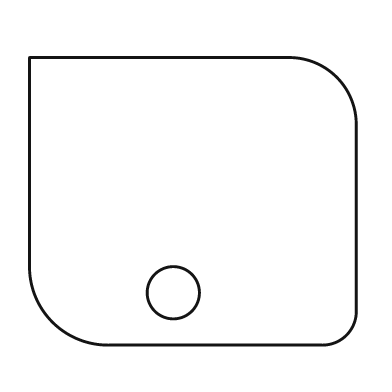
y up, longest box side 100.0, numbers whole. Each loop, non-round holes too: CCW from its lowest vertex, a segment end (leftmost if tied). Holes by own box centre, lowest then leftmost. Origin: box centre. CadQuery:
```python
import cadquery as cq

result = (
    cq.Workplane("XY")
    .moveTo(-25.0, -44.0)
    .lineTo(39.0, -44.0)
    .threePointArc((47.0, -41.0), (50.0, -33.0))
    .lineTo(50.0, 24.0)
    .threePointArc((44.0, 38.0), (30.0, 44.0))
    .lineTo(-50.0, 44.0)
    .lineTo(-50.0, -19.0)
    .threePointArc((-43.0, -37.0), (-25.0, -44.0))
    .close()
    .moveTo(-6.0, -28.0)
    .circle(8.0)
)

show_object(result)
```